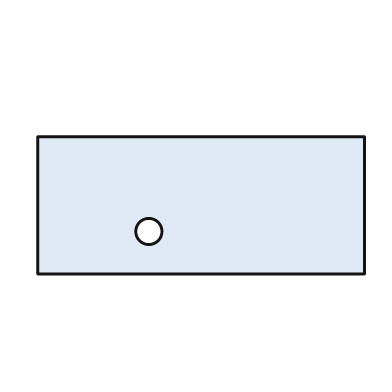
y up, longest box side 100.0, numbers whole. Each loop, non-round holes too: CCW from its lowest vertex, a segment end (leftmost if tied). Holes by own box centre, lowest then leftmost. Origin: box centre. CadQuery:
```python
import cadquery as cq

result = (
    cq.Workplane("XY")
    .moveTo(-50.0, -21.0)
    .lineTo(50.0, -21.0)
    .lineTo(50.0, 21.0)
    .lineTo(-50.0, 21.0)
    .close()
    .moveTo(-16.0, -8.0)
    .circle(4.0)
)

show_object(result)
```